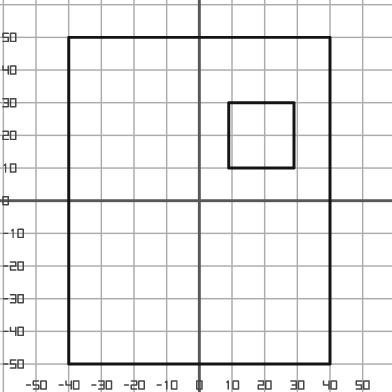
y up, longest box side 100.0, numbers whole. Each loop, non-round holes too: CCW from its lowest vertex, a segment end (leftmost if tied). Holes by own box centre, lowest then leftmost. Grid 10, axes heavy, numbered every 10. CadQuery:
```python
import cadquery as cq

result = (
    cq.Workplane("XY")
    .moveTo(-40.0, -50.0)
    .lineTo(40.0, -50.0)
    .lineTo(40.0, 50.0)
    .lineTo(-40.0, 50.0)
    .close()
    .moveTo(9.0, 10.0)
    .lineTo(29.0, 10.0)
    .lineTo(29.0, 30.0)
    .lineTo(9.0, 30.0)
    .close()
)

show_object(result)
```